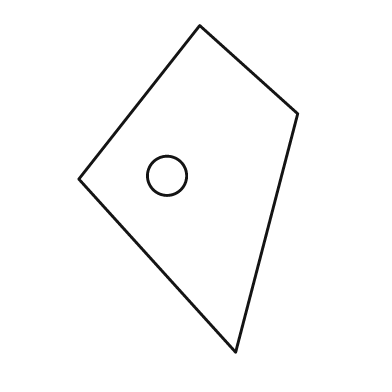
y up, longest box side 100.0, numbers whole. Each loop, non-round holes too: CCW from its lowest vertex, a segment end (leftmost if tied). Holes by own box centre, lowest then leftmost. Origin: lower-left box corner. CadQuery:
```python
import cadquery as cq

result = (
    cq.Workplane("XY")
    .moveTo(48.0, 0.0)
    .lineTo(67.0, 73.0)
    .lineTo(37.0, 100.0)
    .lineTo(0.0, 53.0)
    .close()
    .moveTo(27.0, 54.0)
    .circle(6.0)
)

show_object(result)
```